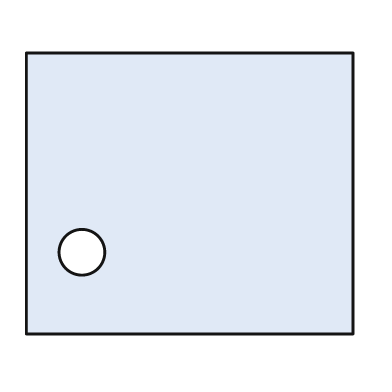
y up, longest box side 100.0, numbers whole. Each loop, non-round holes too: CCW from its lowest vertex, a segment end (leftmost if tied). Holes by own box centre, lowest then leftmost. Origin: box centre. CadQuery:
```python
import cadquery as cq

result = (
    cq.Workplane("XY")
    .moveTo(-50.0, -43.0)
    .lineTo(50.0, -43.0)
    .lineTo(50.0, 43.0)
    .lineTo(-50.0, 43.0)
    .close()
    .moveTo(-33.0, -18.0)
    .circle(7.0)
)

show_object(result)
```